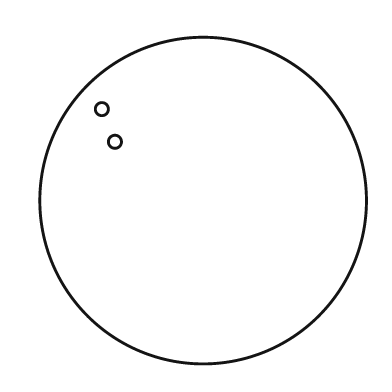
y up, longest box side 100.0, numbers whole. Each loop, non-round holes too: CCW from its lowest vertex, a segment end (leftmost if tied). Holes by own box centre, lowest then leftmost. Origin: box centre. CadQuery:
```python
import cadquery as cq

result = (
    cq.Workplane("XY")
    .moveTo(0.0, 0.0)
    .circle(50.0)
    .moveTo(-27.0, 18.0)
    .circle(2.0)
    .moveTo(-31.0, 28.0)
    .circle(2.0)
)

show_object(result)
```